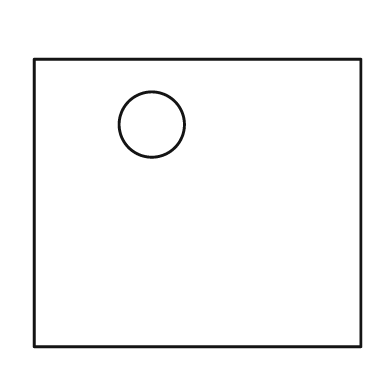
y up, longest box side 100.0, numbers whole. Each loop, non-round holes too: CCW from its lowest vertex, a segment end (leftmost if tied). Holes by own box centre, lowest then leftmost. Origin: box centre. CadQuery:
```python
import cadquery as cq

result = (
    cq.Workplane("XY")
    .moveTo(-50.0, -44.0)
    .lineTo(50.0, -44.0)
    .lineTo(50.0, 44.0)
    .lineTo(-50.0, 44.0)
    .close()
    .moveTo(-14.0, 24.0)
    .circle(10.0)
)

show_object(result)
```